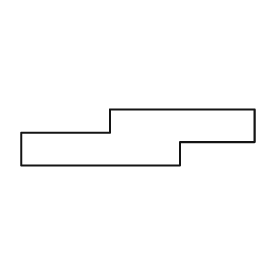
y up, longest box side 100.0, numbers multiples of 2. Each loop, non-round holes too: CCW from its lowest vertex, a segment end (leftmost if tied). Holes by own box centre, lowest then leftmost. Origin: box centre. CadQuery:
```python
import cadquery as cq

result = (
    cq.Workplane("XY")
    .moveTo(-50.0, -12.0)
    .lineTo(18.0, -12.0)
    .lineTo(18.0, -2.0)
    .lineTo(50.0, -2.0)
    .lineTo(50.0, 12.0)
    .lineTo(-12.0, 12.0)
    .lineTo(-12.0, 2.0)
    .lineTo(-50.0, 2.0)
    .close()
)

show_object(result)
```